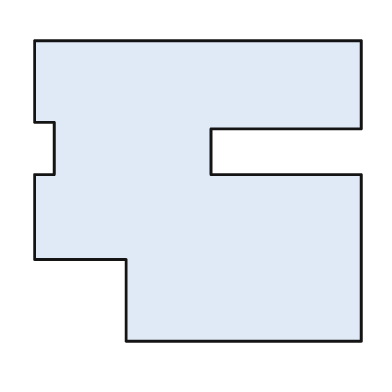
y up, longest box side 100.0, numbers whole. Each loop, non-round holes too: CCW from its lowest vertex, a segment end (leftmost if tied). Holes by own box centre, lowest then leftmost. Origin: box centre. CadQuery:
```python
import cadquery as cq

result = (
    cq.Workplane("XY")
    .moveTo(-22.0, -46.0)
    .lineTo(50.0, -46.0)
    .lineTo(50.0, 5.0)
    .lineTo(4.0, 5.0)
    .lineTo(4.0, 19.0)
    .lineTo(50.0, 19.0)
    .lineTo(50.0, 46.0)
    .lineTo(-50.0, 46.0)
    .lineTo(-50.0, 21.0)
    .lineTo(-44.0, 21.0)
    .lineTo(-44.0, 5.0)
    .lineTo(-50.0, 5.0)
    .lineTo(-50.0, -21.0)
    .lineTo(-22.0, -21.0)
    .close()
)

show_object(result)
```